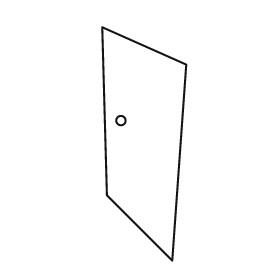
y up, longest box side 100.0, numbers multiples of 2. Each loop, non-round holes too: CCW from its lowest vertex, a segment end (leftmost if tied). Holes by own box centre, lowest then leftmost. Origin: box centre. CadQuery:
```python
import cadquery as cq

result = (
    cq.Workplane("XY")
    .moveTo(12.0, -50.0)
    .lineTo(18.0, 34.0)
    .lineTo(-18.0, 50.0)
    .lineTo(-16.0, -22.0)
    .close()
    .moveTo(-10.0, 10.0)
    .circle(2.0)
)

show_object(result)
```